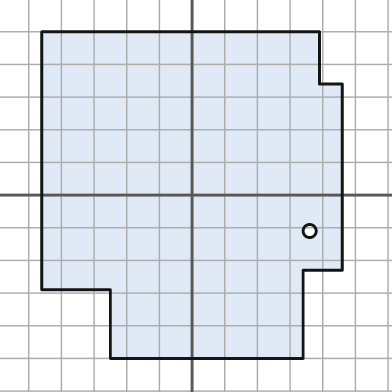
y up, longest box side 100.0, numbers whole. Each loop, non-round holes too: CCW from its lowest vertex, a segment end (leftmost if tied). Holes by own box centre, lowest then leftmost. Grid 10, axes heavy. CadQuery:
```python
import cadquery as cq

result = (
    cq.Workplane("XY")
    .moveTo(-25.0, -50.0)
    .lineTo(34.0, -50.0)
    .lineTo(34.0, -23.0)
    .lineTo(46.0, -23.0)
    .lineTo(46.0, 34.0)
    .lineTo(39.0, 34.0)
    .lineTo(39.0, 50.0)
    .lineTo(-46.0, 50.0)
    .lineTo(-46.0, -29.0)
    .lineTo(-25.0, -29.0)
    .close()
    .moveTo(36.0, -11.0)
    .circle(2.0)
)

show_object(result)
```